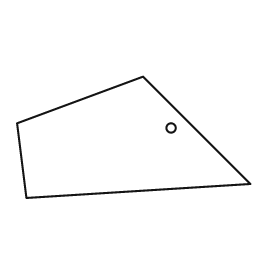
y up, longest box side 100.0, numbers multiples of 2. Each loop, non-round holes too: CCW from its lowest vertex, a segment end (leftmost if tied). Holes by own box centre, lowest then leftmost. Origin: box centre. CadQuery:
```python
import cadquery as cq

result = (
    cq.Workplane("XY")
    .moveTo(-46.0, -26.0)
    .lineTo(50.0, -20.0)
    .lineTo(4.0, 26.0)
    .lineTo(-50.0, 6.0)
    .close()
    .moveTo(16.0, 4.0)
    .circle(2.0)
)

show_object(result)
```